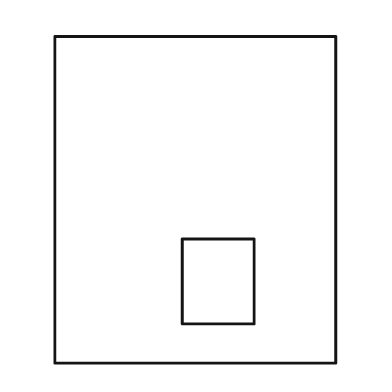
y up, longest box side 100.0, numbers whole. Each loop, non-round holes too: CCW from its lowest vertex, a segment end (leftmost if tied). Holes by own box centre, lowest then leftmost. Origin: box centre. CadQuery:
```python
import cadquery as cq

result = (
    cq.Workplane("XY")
    .moveTo(-43.0, -50.0)
    .lineTo(43.0, -50.0)
    .lineTo(43.0, 50.0)
    .lineTo(-43.0, 50.0)
    .close()
    .moveTo(-4.0, -38.0)
    .lineTo(18.0, -38.0)
    .lineTo(18.0, -12.0)
    .lineTo(-4.0, -12.0)
    .close()
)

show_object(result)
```